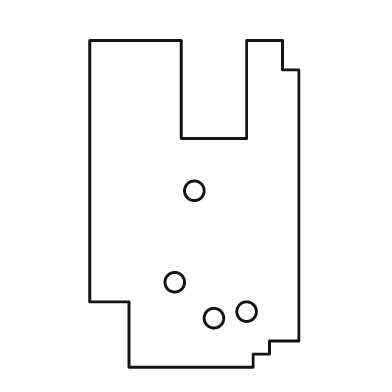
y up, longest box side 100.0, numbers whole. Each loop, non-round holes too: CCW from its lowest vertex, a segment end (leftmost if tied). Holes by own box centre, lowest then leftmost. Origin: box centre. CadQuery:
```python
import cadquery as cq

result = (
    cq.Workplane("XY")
    .moveTo(-20.0, -50.0)
    .lineTo(18.0, -50.0)
    .lineTo(18.0, -46.0)
    .lineTo(23.0, -46.0)
    .lineTo(23.0, -42.0)
    .lineTo(32.0, -42.0)
    .lineTo(32.0, 41.0)
    .lineTo(27.0, 41.0)
    .lineTo(27.0, 50.0)
    .lineTo(16.0, 50.0)
    .lineTo(16.0, 20.0)
    .lineTo(-4.0, 20.0)
    .lineTo(-4.0, 50.0)
    .lineTo(-32.0, 50.0)
    .lineTo(-32.0, -30.0)
    .lineTo(-20.0, -30.0)
    .close()
    .moveTo(6.0, -35.0)
    .circle(3.0)
    .moveTo(16.0, -33.0)
    .circle(3.0)
    .moveTo(-6.0, -24.0)
    .circle(3.0)
    .moveTo(0.0, 4.0)
    .circle(3.0)
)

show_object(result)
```